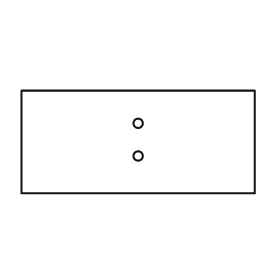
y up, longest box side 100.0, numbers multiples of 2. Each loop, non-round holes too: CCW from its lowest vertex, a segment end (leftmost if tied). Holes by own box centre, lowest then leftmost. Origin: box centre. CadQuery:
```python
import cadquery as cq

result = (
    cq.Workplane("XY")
    .moveTo(-50.0, -22.0)
    .lineTo(50.0, -22.0)
    .lineTo(50.0, 22.0)
    .lineTo(-50.0, 22.0)
    .close()
    .moveTo(0.0, -6.0)
    .circle(2.0)
    .moveTo(0.0, 8.0)
    .circle(2.0)
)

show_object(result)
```